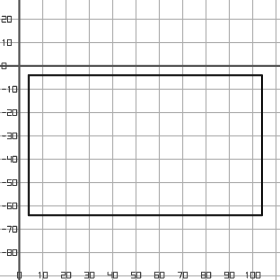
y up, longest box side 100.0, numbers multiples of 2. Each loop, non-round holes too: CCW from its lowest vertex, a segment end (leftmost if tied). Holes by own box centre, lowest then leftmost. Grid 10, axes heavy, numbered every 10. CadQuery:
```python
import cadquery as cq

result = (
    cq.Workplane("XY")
    .moveTo(4.0, -64.0)
    .lineTo(104.0, -64.0)
    .lineTo(104.0, -4.0)
    .lineTo(4.0, -4.0)
    .close()
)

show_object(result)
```